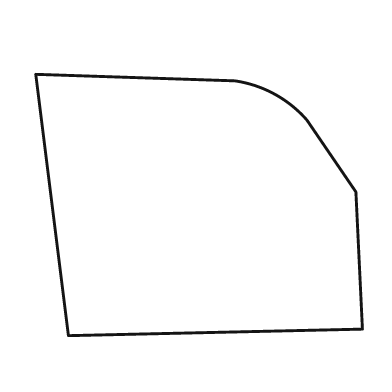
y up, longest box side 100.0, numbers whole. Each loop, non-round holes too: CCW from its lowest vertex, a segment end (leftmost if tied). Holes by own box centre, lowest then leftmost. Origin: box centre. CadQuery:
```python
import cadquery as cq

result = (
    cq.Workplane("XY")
    .moveTo(-40.0, -40.0)
    .lineTo(50.0, -38.0)
    .lineTo(48.0, 4.0)
    .lineTo(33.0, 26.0)
    .threePointArc((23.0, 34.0), (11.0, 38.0))
    .lineTo(-50.0, 40.0)
    .close()
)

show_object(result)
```